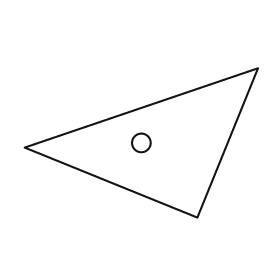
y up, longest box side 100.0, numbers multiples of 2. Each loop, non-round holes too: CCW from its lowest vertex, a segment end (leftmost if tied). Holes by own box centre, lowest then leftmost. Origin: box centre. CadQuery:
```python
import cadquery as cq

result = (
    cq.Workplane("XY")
    .moveTo(24.0, -32.0)
    .lineTo(50.0, 32.0)
    .lineTo(-50.0, -2.0)
    .close()
    .moveTo(0.0, 0.0)
    .circle(4.0)
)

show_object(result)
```